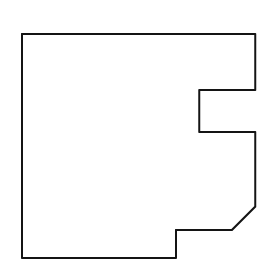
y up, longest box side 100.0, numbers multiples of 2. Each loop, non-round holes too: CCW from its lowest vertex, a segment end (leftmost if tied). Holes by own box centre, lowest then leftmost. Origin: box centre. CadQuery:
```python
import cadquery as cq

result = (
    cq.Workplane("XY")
    .moveTo(-50.0, -48.0)
    .lineTo(16.0, -48.0)
    .lineTo(16.0, -36.0)
    .lineTo(40.0, -36.0)
    .lineTo(50.0, -26.0)
    .lineTo(50.0, 6.0)
    .lineTo(26.0, 6.0)
    .lineTo(26.0, 24.0)
    .lineTo(50.0, 24.0)
    .lineTo(50.0, 48.0)
    .lineTo(-50.0, 48.0)
    .close()
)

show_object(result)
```